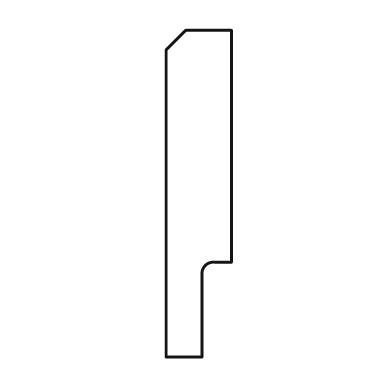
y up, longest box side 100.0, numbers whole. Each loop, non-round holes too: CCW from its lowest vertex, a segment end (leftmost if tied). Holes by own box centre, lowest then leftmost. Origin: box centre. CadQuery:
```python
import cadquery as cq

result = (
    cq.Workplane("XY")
    .moveTo(-10.0, -50.0)
    .lineTo(1.0, -50.0)
    .lineTo(1.0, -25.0)
    .threePointArc((2.0, -22.0), (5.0, -21.0))
    .lineTo(10.0, -21.0)
    .lineTo(10.0, 50.0)
    .lineTo(-4.0, 50.0)
    .lineTo(-10.0, 44.0)
    .close()
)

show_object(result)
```